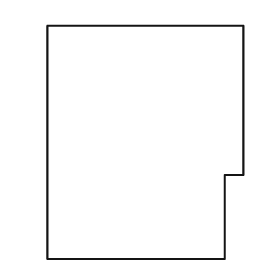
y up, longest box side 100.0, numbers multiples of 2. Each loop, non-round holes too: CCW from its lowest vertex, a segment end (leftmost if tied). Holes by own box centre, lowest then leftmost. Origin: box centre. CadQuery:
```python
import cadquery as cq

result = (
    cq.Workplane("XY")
    .moveTo(-42.0, -50.0)
    .lineTo(34.0, -50.0)
    .lineTo(34.0, -14.0)
    .lineTo(42.0, -14.0)
    .lineTo(42.0, 50.0)
    .lineTo(-42.0, 50.0)
    .close()
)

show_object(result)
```